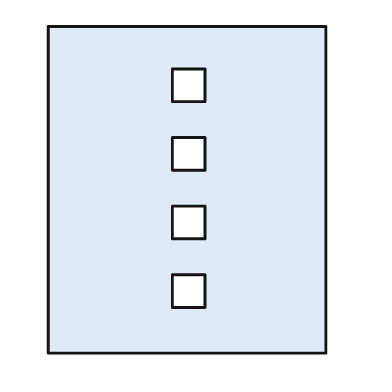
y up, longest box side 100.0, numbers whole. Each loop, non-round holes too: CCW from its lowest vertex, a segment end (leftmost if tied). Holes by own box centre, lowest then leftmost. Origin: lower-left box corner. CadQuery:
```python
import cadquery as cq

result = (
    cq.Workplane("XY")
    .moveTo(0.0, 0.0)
    .lineTo(85.0, 0.0)
    .lineTo(85.0, 100.0)
    .lineTo(0.0, 100.0)
    .close()
    .moveTo(38.0, 14.0)
    .lineTo(48.0, 14.0)
    .lineTo(48.0, 24.0)
    .lineTo(38.0, 24.0)
    .close()
    .moveTo(38.0, 35.0)
    .lineTo(48.0, 35.0)
    .lineTo(48.0, 45.0)
    .lineTo(38.0, 45.0)
    .close()
    .moveTo(38.0, 56.0)
    .lineTo(48.0, 56.0)
    .lineTo(48.0, 66.0)
    .lineTo(38.0, 66.0)
    .close()
    .moveTo(38.0, 77.0)
    .lineTo(48.0, 77.0)
    .lineTo(48.0, 87.0)
    .lineTo(38.0, 87.0)
    .close()
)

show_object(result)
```